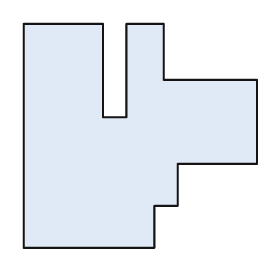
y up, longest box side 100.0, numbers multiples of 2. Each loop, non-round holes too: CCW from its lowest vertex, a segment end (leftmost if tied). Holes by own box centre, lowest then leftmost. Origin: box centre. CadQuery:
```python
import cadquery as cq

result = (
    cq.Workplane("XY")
    .moveTo(-50.0, -48.0)
    .lineTo(6.0, -48.0)
    .lineTo(6.0, -30.0)
    .lineTo(16.0, -30.0)
    .lineTo(16.0, -12.0)
    .lineTo(50.0, -12.0)
    .lineTo(50.0, 24.0)
    .lineTo(10.0, 24.0)
    .lineTo(10.0, 48.0)
    .lineTo(-6.0, 48.0)
    .lineTo(-6.0, 8.0)
    .lineTo(-16.0, 8.0)
    .lineTo(-16.0, 48.0)
    .lineTo(-50.0, 48.0)
    .close()
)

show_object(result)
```